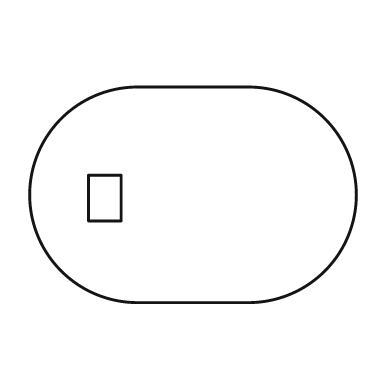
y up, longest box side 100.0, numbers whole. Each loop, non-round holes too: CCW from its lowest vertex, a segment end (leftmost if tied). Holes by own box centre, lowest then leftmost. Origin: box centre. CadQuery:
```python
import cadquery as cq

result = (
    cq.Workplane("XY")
    .moveTo(-17.0, -33.0)
    .lineTo(17.0, -33.0)
    .threePointArc((50.0, 0.0), (17.0, 33.0))
    .lineTo(-17.0, 33.0)
    .threePointArc((-50.0, 0.0), (-17.0, -33.0))
    .close()
    .moveTo(-32.0, -8.0)
    .lineTo(-22.0, -8.0)
    .lineTo(-22.0, 6.0)
    .lineTo(-32.0, 6.0)
    .close()
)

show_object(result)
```